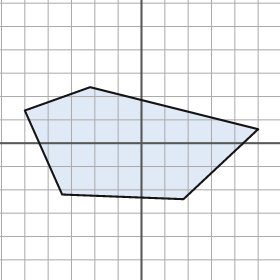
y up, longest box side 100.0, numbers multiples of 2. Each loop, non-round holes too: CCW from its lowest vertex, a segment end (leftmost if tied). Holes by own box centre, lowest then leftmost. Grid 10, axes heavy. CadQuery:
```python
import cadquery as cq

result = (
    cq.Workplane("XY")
    .moveTo(18.0, -24.0)
    .lineTo(50.0, 6.0)
    .lineTo(-22.0, 24.0)
    .lineTo(-50.0, 14.0)
    .lineTo(-34.0, -22.0)
    .close()
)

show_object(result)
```